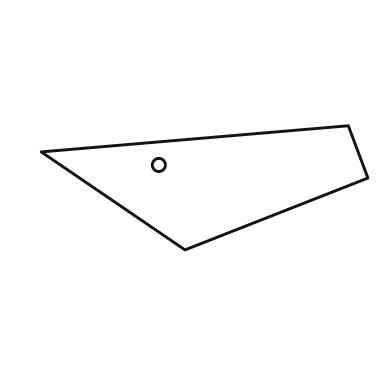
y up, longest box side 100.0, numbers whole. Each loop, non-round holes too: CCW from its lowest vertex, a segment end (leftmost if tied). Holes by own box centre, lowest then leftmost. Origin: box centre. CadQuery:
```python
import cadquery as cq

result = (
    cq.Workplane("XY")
    .moveTo(-6.0, -19.0)
    .lineTo(50.0, 3.0)
    .lineTo(44.0, 19.0)
    .lineTo(-50.0, 11.0)
    .close()
    .moveTo(-14.0, 7.0)
    .circle(2.0)
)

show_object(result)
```